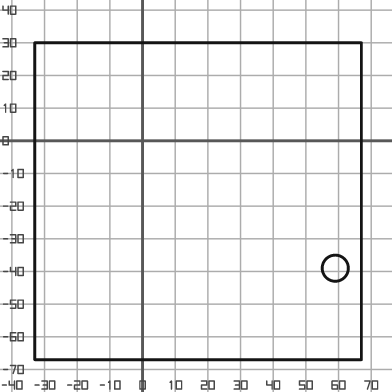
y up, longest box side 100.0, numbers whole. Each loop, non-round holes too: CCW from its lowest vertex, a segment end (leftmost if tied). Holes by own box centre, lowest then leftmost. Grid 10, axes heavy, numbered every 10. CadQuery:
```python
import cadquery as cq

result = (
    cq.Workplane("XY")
    .moveTo(-33.0, -67.0)
    .lineTo(67.0, -67.0)
    .lineTo(67.0, 30.0)
    .lineTo(-33.0, 30.0)
    .close()
    .moveTo(59.0, -39.0)
    .circle(4.0)
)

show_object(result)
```